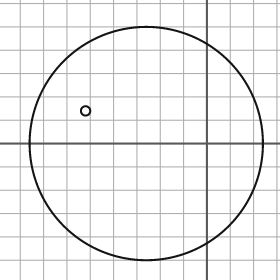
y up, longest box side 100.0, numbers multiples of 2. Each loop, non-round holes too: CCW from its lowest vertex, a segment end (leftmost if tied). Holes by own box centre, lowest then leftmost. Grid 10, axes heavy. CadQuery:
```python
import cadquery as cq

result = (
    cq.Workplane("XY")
    .moveTo(-26.0, 0.0)
    .circle(50.0)
    .moveTo(-52.0, 14.0)
    .circle(2.0)
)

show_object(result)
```